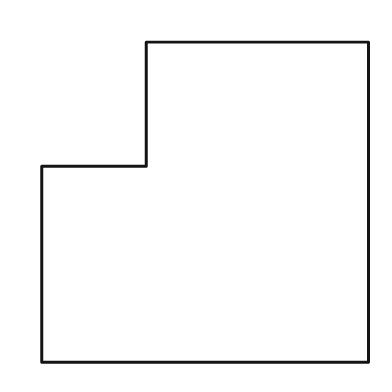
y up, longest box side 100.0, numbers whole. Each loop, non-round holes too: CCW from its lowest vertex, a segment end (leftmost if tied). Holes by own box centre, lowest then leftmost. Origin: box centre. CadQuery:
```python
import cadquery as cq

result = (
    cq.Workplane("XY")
    .moveTo(-50.0, -49.0)
    .lineTo(50.0, -49.0)
    .lineTo(50.0, 49.0)
    .lineTo(-18.0, 49.0)
    .lineTo(-18.0, 11.0)
    .lineTo(-50.0, 11.0)
    .close()
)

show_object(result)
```